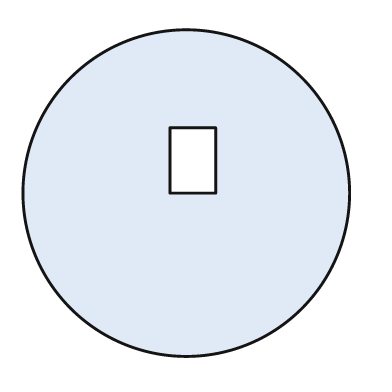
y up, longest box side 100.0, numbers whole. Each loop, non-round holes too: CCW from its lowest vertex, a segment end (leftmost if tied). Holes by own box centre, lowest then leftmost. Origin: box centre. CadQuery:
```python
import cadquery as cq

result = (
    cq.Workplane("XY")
    .moveTo(0.0, 0.0)
    .circle(50.0)
    .moveTo(-5.0, 0.0)
    .lineTo(9.0, 0.0)
    .lineTo(9.0, 20.0)
    .lineTo(-5.0, 20.0)
    .close()
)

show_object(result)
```